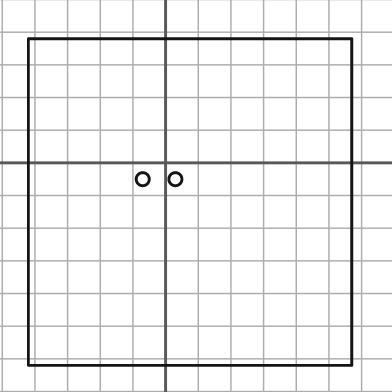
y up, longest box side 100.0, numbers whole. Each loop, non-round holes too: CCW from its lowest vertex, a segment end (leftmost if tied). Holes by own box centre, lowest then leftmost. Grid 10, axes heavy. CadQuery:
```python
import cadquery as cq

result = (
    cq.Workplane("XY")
    .moveTo(-42.0, -62.0)
    .lineTo(57.0, -62.0)
    .lineTo(57.0, 38.0)
    .lineTo(-42.0, 38.0)
    .close()
    .moveTo(-7.0, -5.0)
    .circle(2.0)
    .moveTo(3.0, -5.0)
    .circle(2.0)
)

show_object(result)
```